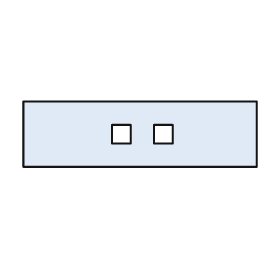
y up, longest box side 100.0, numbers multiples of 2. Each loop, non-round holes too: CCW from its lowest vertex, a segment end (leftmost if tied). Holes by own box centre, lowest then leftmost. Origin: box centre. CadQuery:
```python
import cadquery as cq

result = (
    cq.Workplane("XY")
    .moveTo(-50.0, -14.0)
    .lineTo(50.0, -14.0)
    .lineTo(50.0, 14.0)
    .lineTo(-50.0, 14.0)
    .close()
    .moveTo(-12.0, -4.0)
    .lineTo(-4.0, -4.0)
    .lineTo(-4.0, 4.0)
    .lineTo(-12.0, 4.0)
    .close()
    .moveTo(6.0, -4.0)
    .lineTo(14.0, -4.0)
    .lineTo(14.0, 4.0)
    .lineTo(6.0, 4.0)
    .close()
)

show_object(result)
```